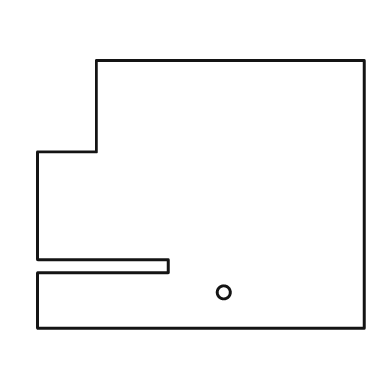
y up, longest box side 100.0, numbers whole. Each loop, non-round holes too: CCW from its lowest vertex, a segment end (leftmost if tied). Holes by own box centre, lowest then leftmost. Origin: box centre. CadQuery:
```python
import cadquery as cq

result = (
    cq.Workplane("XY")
    .moveTo(-50.0, -41.0)
    .lineTo(50.0, -41.0)
    .lineTo(50.0, 41.0)
    .lineTo(-32.0, 41.0)
    .lineTo(-32.0, 13.0)
    .lineTo(-50.0, 13.0)
    .lineTo(-50.0, -20.0)
    .lineTo(-10.0, -20.0)
    .lineTo(-10.0, -24.0)
    .lineTo(-50.0, -24.0)
    .close()
    .moveTo(7.0, -30.0)
    .circle(2.0)
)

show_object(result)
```